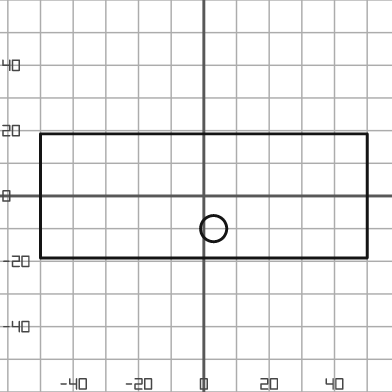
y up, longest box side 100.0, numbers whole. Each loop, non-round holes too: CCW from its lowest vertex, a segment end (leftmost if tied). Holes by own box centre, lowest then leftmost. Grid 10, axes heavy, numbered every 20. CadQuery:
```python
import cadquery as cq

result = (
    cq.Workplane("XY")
    .moveTo(-50.0, -19.0)
    .lineTo(50.0, -19.0)
    .lineTo(50.0, 19.0)
    .lineTo(-50.0, 19.0)
    .close()
    .moveTo(3.0, -10.0)
    .circle(4.0)
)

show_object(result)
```